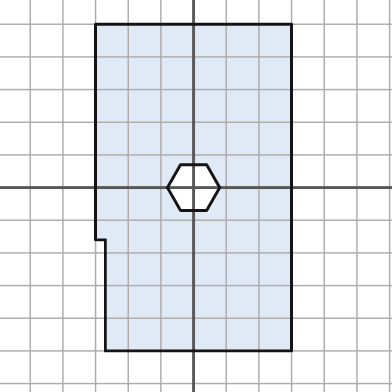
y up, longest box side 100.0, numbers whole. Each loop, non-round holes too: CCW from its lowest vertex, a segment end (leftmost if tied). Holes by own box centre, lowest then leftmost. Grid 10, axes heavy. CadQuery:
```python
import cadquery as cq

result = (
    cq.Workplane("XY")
    .moveTo(-27.0, -50.0)
    .lineTo(30.0, -50.0)
    .lineTo(30.0, 50.0)
    .lineTo(-30.0, 50.0)
    .lineTo(-30.0, -16.0)
    .lineTo(-27.0, -16.0)
    .close()
    .moveTo(-4.0, -7.0)
    .lineTo(4.0, -7.0)
    .lineTo(8.0, 0.0)
    .lineTo(4.0, 7.0)
    .lineTo(-4.0, 7.0)
    .lineTo(-8.0, 0.0)
    .close()
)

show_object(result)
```